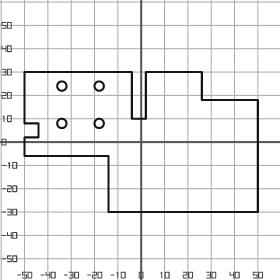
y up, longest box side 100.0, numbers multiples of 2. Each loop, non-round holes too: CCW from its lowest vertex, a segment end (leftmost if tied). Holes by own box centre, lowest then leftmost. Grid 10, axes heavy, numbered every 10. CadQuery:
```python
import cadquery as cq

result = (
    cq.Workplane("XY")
    .moveTo(-14.0, -30.0)
    .lineTo(50.0, -30.0)
    .lineTo(50.0, 18.0)
    .lineTo(26.0, 18.0)
    .lineTo(26.0, 30.0)
    .lineTo(2.0, 30.0)
    .lineTo(2.0, 10.0)
    .lineTo(-4.0, 10.0)
    .lineTo(-4.0, 30.0)
    .lineTo(-50.0, 30.0)
    .lineTo(-50.0, 8.0)
    .lineTo(-44.0, 8.0)
    .lineTo(-44.0, 2.0)
    .lineTo(-50.0, 2.0)
    .lineTo(-50.0, -6.0)
    .lineTo(-14.0, -6.0)
    .close()
    .moveTo(-34.0, 8.0)
    .circle(2.0)
    .moveTo(-18.0, 8.0)
    .circle(2.0)
    .moveTo(-34.0, 24.0)
    .circle(2.0)
    .moveTo(-18.0, 24.0)
    .circle(2.0)
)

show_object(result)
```